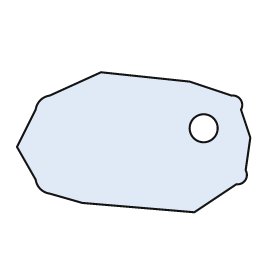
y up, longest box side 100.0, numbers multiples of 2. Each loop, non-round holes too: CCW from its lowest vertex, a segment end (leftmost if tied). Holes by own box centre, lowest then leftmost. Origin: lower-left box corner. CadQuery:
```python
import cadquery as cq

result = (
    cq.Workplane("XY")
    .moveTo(76.0, 0.0)
    .lineTo(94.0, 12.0)
    .threePointArc((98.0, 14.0), (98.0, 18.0))
    .lineTo(100.0, 32.0)
    .lineTo(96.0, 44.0)
    .threePointArc((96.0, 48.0), (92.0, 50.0))
    .lineTo(74.0, 56.0)
    .lineTo(36.0, 60.0)
    .lineTo(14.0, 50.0)
    .threePointArc((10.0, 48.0), (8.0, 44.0))
    .lineTo(0.0, 28.0)
    .lineTo(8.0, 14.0)
    .threePointArc((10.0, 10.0), (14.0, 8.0))
    .lineTo(28.0, 4.0)
    .close()
    .moveTo(80.0, 36.0)
    .circle(6.0)
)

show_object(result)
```